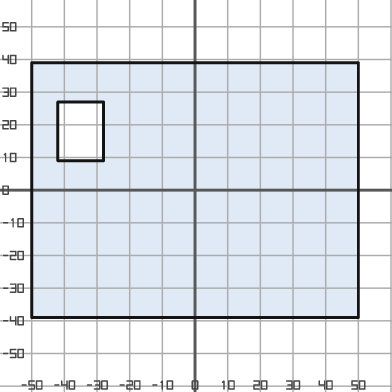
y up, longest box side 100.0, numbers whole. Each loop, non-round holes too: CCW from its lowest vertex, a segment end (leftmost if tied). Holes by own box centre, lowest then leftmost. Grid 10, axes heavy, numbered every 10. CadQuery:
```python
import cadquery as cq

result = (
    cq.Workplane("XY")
    .moveTo(-50.0, -39.0)
    .lineTo(50.0, -39.0)
    .lineTo(50.0, 39.0)
    .lineTo(-50.0, 39.0)
    .close()
    .moveTo(-42.0, 9.0)
    .lineTo(-28.0, 9.0)
    .lineTo(-28.0, 27.0)
    .lineTo(-42.0, 27.0)
    .close()
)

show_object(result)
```